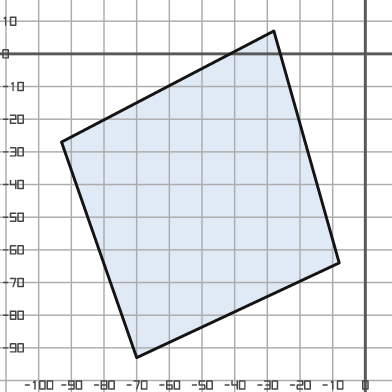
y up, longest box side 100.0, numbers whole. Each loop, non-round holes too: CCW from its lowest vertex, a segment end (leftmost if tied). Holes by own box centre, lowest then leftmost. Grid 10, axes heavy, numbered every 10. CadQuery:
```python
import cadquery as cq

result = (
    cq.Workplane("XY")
    .moveTo(-70.0, -93.0)
    .lineTo(-8.0, -64.0)
    .lineTo(-28.0, 7.0)
    .lineTo(-93.0, -27.0)
    .close()
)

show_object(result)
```